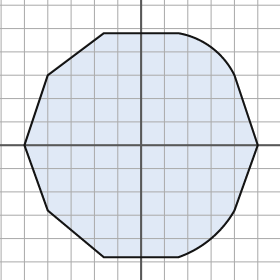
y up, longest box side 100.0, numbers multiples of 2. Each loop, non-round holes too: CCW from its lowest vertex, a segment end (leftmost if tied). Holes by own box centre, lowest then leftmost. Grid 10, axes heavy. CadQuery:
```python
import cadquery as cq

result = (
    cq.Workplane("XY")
    .moveTo(-16.0, -48.0)
    .lineTo(16.0, -48.0)
    .threePointArc((30.0, -40.0), (40.0, -28.0))
    .lineTo(50.0, 0.0)
    .lineTo(40.0, 30.0)
    .threePointArc((30.0, 42.0), (16.0, 48.0))
    .lineTo(-16.0, 48.0)
    .lineTo(-40.0, 30.0)
    .lineTo(-50.0, 0.0)
    .lineTo(-40.0, -28.0)
    .close()
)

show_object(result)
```